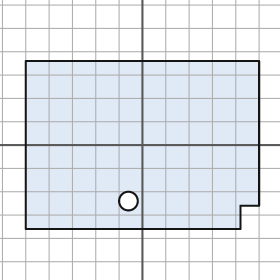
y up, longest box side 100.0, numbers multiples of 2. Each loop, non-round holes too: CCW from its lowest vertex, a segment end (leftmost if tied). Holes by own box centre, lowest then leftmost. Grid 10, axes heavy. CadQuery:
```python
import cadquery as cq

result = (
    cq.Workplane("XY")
    .moveTo(-50.0, -36.0)
    .lineTo(42.0, -36.0)
    .lineTo(42.0, -26.0)
    .lineTo(50.0, -26.0)
    .lineTo(50.0, 36.0)
    .lineTo(-50.0, 36.0)
    .close()
    .moveTo(-6.0, -24.0)
    .circle(4.0)
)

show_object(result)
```